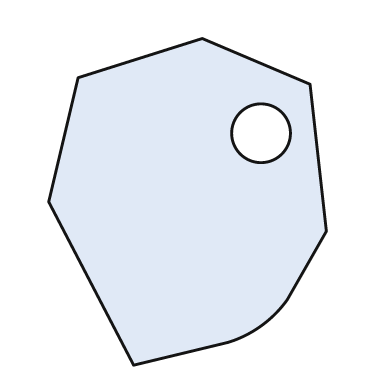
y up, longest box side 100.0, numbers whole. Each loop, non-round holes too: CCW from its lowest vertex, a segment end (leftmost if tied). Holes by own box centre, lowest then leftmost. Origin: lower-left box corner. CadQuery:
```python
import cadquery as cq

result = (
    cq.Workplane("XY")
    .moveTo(26.0, 0.0)
    .lineTo(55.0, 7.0)
    .threePointArc((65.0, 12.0), (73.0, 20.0))
    .lineTo(85.0, 41.0)
    .lineTo(80.0, 86.0)
    .lineTo(47.0, 100.0)
    .lineTo(9.0, 88.0)
    .lineTo(0.0, 50.0)
    .close()
    .moveTo(65.0, 71.0)
    .circle(9.0)
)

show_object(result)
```